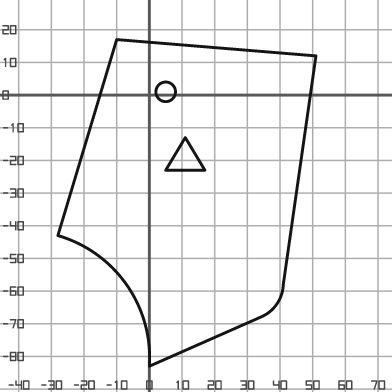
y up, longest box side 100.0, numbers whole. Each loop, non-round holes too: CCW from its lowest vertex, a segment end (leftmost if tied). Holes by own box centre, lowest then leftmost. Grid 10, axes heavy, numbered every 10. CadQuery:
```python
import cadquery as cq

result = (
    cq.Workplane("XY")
    .moveTo(0.0, -83.0)
    .lineTo(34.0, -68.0)
    .threePointArc((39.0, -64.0), (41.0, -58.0))
    .lineTo(51.0, 12.0)
    .lineTo(-10.0, 17.0)
    .lineTo(-28.0, -43.0)
    .threePointArc((-7.0, -58.0), (0.0, -83.0))
    .close()
    .moveTo(5.0, -23.0)
    .lineTo(17.0, -23.0)
    .lineTo(11.0, -13.0)
    .close()
    .moveTo(5.0, 1.0)
    .circle(3.0)
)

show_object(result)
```